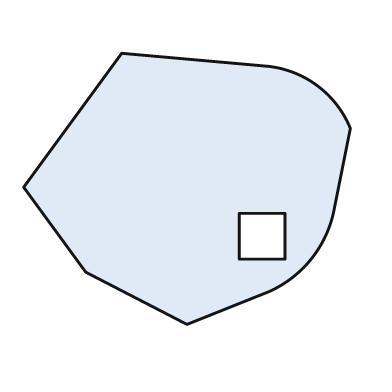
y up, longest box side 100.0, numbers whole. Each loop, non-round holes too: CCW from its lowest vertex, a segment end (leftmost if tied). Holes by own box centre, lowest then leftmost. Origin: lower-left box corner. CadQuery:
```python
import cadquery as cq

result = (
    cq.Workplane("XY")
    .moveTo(50.0, 0.0)
    .lineTo(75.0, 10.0)
    .threePointArc((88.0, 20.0), (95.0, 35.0))
    .lineTo(100.0, 60.0)
    .threePointArc((90.0, 73.0), (75.0, 79.0))
    .lineTo(30.0, 83.0)
    .lineTo(0.0, 42.0)
    .lineTo(19.0, 16.0)
    .close()
    .moveTo(66.0, 20.0)
    .lineTo(80.0, 20.0)
    .lineTo(80.0, 34.0)
    .lineTo(66.0, 34.0)
    .close()
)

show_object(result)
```